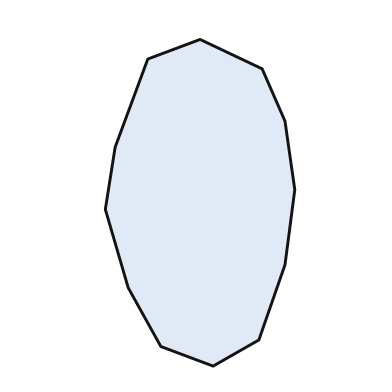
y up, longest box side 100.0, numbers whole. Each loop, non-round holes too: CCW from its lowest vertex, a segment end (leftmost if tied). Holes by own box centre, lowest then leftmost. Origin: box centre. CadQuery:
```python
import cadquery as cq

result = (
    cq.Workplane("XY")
    .moveTo(4.0, -50.0)
    .lineTo(18.0, -42.0)
    .lineTo(26.0, -19.0)
    .lineTo(29.0, 4.0)
    .lineTo(26.0, 25.0)
    .lineTo(19.0, 41.0)
    .lineTo(0.0, 50.0)
    .lineTo(-16.0, 44.0)
    .lineTo(-26.0, 17.0)
    .lineTo(-29.0, -2.0)
    .lineTo(-22.0, -26.0)
    .lineTo(-12.0, -44.0)
    .close()
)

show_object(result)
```